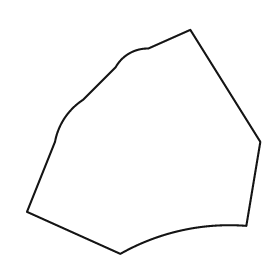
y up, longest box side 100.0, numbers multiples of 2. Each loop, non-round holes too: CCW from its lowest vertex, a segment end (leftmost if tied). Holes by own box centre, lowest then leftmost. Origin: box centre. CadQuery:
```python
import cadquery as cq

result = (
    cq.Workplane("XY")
    .moveTo(-10.0, -48.0)
    .threePointArc((16.0, -38.0), (44.0, -36.0))
    .lineTo(50.0, 0.0)
    .lineTo(20.0, 48.0)
    .lineTo(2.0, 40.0)
    .threePointArc((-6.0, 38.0), (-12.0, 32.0))
    .lineTo(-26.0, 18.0)
    .threePointArc((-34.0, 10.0), (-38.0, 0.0))
    .lineTo(-50.0, -30.0)
    .close()
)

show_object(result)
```